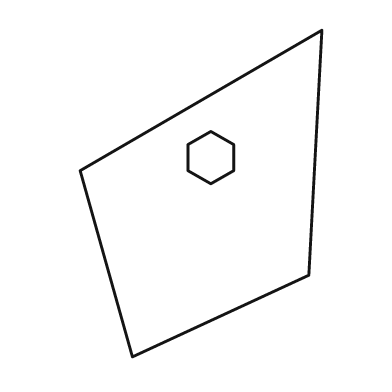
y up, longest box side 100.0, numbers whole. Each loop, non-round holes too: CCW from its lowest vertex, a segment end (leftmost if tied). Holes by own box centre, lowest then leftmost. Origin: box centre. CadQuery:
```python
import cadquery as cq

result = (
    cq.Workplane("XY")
    .moveTo(-21.0, -50.0)
    .lineTo(33.0, -25.0)
    .lineTo(37.0, 50.0)
    .lineTo(-37.0, 7.0)
    .close()
    .moveTo(3.0, 3.0)
    .lineTo(10.0, 7.0)
    .lineTo(10.0, 15.0)
    .lineTo(3.0, 19.0)
    .lineTo(-4.0, 15.0)
    .lineTo(-4.0, 7.0)
    .close()
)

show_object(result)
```